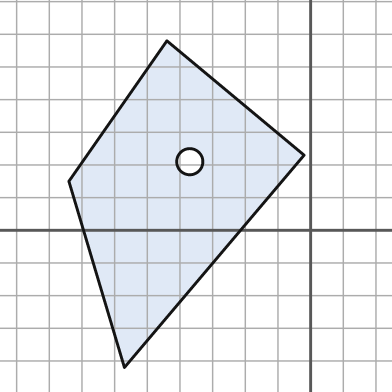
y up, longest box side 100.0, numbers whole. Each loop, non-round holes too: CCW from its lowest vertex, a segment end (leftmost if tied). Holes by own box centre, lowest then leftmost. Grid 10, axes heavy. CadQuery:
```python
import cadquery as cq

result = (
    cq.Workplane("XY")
    .moveTo(-57.0, -42.0)
    .lineTo(-2.0, 23.0)
    .lineTo(-44.0, 58.0)
    .lineTo(-74.0, 15.0)
    .close()
    .moveTo(-37.0, 21.0)
    .circle(4.0)
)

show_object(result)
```